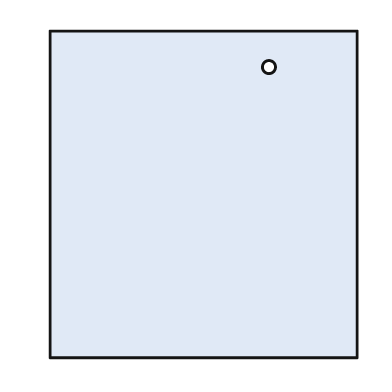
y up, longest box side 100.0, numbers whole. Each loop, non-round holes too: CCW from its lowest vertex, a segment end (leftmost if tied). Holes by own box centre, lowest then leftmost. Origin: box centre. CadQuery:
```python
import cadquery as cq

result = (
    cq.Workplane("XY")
    .moveTo(-47.0, -50.0)
    .lineTo(47.0, -50.0)
    .lineTo(47.0, 50.0)
    .lineTo(-47.0, 50.0)
    .close()
    .moveTo(20.0, 39.0)
    .circle(2.0)
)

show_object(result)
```